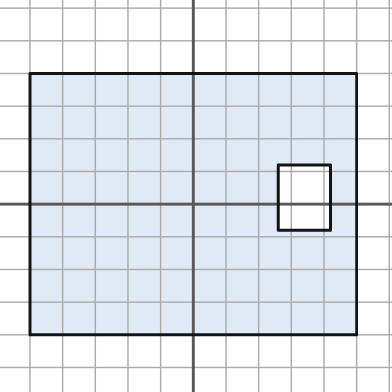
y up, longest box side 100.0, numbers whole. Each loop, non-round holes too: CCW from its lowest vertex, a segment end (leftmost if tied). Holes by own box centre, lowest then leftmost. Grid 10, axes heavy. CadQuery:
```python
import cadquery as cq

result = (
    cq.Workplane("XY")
    .moveTo(-50.0, -40.0)
    .lineTo(50.0, -40.0)
    .lineTo(50.0, 40.0)
    .lineTo(-50.0, 40.0)
    .close()
    .moveTo(26.0, -8.0)
    .lineTo(42.0, -8.0)
    .lineTo(42.0, 12.0)
    .lineTo(26.0, 12.0)
    .close()
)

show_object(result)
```